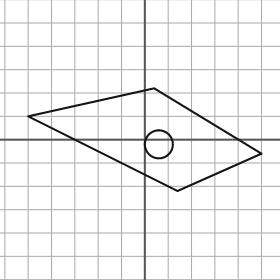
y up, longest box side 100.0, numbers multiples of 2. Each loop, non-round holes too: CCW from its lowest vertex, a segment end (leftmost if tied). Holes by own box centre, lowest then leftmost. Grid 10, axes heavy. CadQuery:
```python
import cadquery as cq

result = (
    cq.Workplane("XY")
    .moveTo(14.0, -22.0)
    .lineTo(50.0, -6.0)
    .lineTo(4.0, 22.0)
    .lineTo(-50.0, 10.0)
    .close()
    .moveTo(6.0, -2.0)
    .circle(6.0)
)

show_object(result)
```